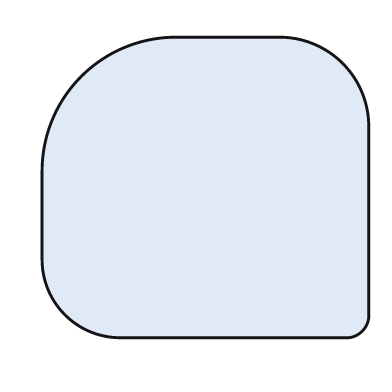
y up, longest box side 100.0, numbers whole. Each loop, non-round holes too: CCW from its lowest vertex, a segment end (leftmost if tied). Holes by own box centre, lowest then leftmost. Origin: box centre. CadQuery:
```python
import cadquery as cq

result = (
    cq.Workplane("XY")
    .moveTo(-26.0, -46.0)
    .lineTo(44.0, -46.0)
    .threePointArc((48.0, -44.0), (50.0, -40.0))
    .lineTo(50.0, 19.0)
    .threePointArc((42.0, 38.0), (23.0, 46.0))
    .lineTo(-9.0, 46.0)
    .threePointArc((-38.0, 34.0), (-50.0, 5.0))
    .lineTo(-50.0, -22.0)
    .threePointArc((-43.0, -39.0), (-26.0, -46.0))
    .close()
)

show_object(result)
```